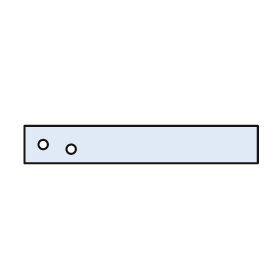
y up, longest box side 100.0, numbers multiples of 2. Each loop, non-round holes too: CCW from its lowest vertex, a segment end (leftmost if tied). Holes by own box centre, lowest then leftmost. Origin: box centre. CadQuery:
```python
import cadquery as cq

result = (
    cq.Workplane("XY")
    .moveTo(-50.0, -8.0)
    .lineTo(50.0, -8.0)
    .lineTo(50.0, 8.0)
    .lineTo(-50.0, 8.0)
    .close()
    .moveTo(-30.0, -2.0)
    .circle(2.0)
    .moveTo(-42.0, 0.0)
    .circle(2.0)
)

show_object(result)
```